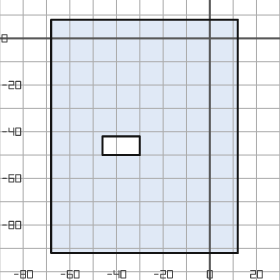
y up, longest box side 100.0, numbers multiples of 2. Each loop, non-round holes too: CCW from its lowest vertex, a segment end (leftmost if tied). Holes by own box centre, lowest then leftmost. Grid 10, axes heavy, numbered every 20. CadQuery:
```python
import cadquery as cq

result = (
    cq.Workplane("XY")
    .moveTo(-68.0, -92.0)
    .lineTo(12.0, -92.0)
    .lineTo(12.0, 8.0)
    .lineTo(-68.0, 8.0)
    .close()
    .moveTo(-46.0, -50.0)
    .lineTo(-30.0, -50.0)
    .lineTo(-30.0, -42.0)
    .lineTo(-46.0, -42.0)
    .close()
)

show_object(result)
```